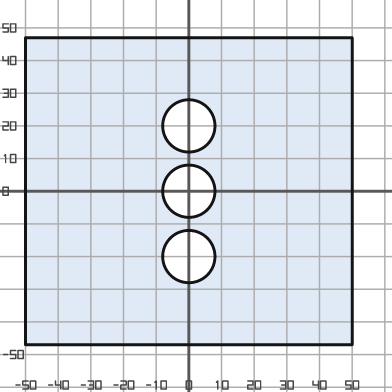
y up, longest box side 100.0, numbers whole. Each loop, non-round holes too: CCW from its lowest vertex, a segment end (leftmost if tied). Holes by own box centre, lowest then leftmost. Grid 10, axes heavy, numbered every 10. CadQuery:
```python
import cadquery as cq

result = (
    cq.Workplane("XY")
    .moveTo(-50.0, -47.0)
    .lineTo(50.0, -47.0)
    .lineTo(50.0, 47.0)
    .lineTo(-50.0, 47.0)
    .close()
    .moveTo(0.0, -20.0)
    .circle(8.0)
    .moveTo(0.0, 0.0)
    .circle(8.0)
    .moveTo(0.0, 20.0)
    .circle(8.0)
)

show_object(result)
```